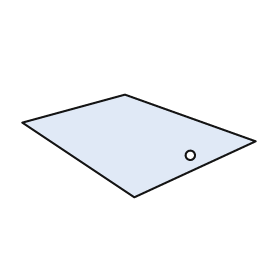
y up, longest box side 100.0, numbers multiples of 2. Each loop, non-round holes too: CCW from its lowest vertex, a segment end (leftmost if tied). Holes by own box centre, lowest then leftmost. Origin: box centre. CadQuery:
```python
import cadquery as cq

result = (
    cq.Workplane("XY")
    .moveTo(-2.0, -22.0)
    .lineTo(50.0, 2.0)
    .lineTo(-6.0, 22.0)
    .lineTo(-50.0, 10.0)
    .close()
    .moveTo(22.0, -4.0)
    .circle(2.0)
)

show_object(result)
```